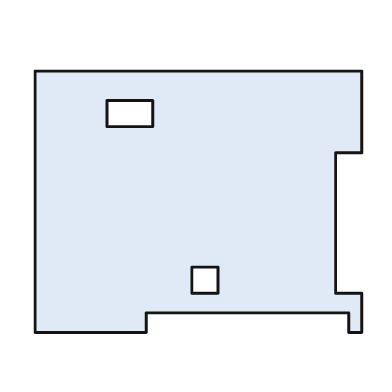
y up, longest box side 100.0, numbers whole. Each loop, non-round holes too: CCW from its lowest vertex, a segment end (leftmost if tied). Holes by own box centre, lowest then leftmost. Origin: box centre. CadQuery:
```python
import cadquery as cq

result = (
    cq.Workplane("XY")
    .moveTo(-50.0, -40.0)
    .lineTo(-16.0, -40.0)
    .lineTo(-16.0, -34.0)
    .lineTo(46.0, -34.0)
    .lineTo(46.0, -40.0)
    .lineTo(50.0, -40.0)
    .lineTo(50.0, -28.0)
    .lineTo(42.0, -28.0)
    .lineTo(42.0, 15.0)
    .lineTo(50.0, 15.0)
    .lineTo(50.0, 40.0)
    .lineTo(-50.0, 40.0)
    .close()
    .moveTo(-2.0, -28.0)
    .lineTo(6.0, -28.0)
    .lineTo(6.0, -20.0)
    .lineTo(-2.0, -20.0)
    .close()
    .moveTo(-28.0, 23.0)
    .lineTo(-14.0, 23.0)
    .lineTo(-14.0, 31.0)
    .lineTo(-28.0, 31.0)
    .close()
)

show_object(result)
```